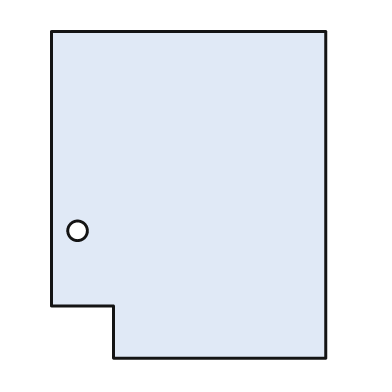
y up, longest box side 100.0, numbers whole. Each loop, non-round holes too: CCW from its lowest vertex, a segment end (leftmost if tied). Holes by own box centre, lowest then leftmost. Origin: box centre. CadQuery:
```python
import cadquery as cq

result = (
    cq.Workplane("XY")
    .moveTo(-23.0, -50.0)
    .lineTo(42.0, -50.0)
    .lineTo(42.0, 50.0)
    .lineTo(-42.0, 50.0)
    .lineTo(-42.0, -34.0)
    .lineTo(-23.0, -34.0)
    .close()
    .moveTo(-34.0, -11.0)
    .circle(3.0)
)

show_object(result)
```